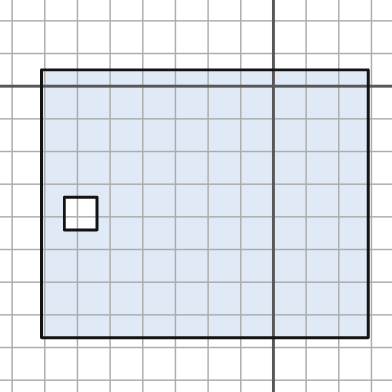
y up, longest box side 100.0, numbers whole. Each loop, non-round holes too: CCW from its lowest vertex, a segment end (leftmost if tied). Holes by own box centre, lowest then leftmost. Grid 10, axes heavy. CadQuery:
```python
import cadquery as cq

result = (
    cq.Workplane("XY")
    .moveTo(-71.0, -77.0)
    .lineTo(29.0, -77.0)
    .lineTo(29.0, 5.0)
    .lineTo(-71.0, 5.0)
    .close()
    .moveTo(-64.0, -44.0)
    .lineTo(-54.0, -44.0)
    .lineTo(-54.0, -34.0)
    .lineTo(-64.0, -34.0)
    .close()
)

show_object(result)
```